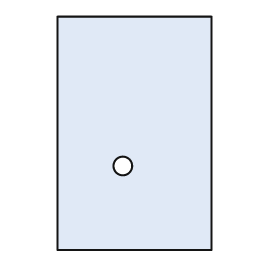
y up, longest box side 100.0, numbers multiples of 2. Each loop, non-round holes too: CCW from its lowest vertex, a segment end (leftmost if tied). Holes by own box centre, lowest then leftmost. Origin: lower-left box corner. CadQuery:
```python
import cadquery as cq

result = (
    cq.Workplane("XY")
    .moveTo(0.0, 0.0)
    .lineTo(66.0, 0.0)
    .lineTo(66.0, 100.0)
    .lineTo(0.0, 100.0)
    .close()
    .moveTo(28.0, 36.0)
    .circle(4.0)
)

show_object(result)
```